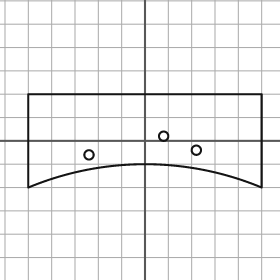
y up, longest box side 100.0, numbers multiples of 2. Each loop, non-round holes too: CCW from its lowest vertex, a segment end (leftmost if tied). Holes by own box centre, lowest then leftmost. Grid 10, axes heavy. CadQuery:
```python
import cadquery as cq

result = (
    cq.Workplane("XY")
    .moveTo(-50.0, -20.0)
    .threePointArc((0.0, -10.0), (50.0, -20.0))
    .lineTo(50.0, 20.0)
    .lineTo(-50.0, 20.0)
    .close()
    .moveTo(-24.0, -6.0)
    .circle(2.0)
    .moveTo(22.0, -4.0)
    .circle(2.0)
    .moveTo(8.0, 2.0)
    .circle(2.0)
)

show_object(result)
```